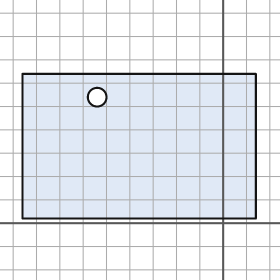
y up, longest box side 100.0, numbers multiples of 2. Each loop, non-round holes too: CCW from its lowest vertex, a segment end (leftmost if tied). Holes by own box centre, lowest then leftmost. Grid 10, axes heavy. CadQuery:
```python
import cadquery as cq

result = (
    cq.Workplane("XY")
    .moveTo(-86.0, 2.0)
    .lineTo(14.0, 2.0)
    .lineTo(14.0, 64.0)
    .lineTo(-86.0, 64.0)
    .close()
    .moveTo(-54.0, 54.0)
    .circle(4.0)
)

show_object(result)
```